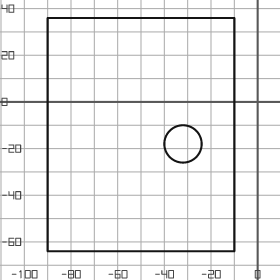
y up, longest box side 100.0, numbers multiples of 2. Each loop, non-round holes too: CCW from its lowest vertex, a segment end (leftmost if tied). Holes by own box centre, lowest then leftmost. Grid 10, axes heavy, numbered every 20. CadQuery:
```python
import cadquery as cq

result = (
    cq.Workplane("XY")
    .moveTo(-90.0, -64.0)
    .lineTo(-10.0, -64.0)
    .lineTo(-10.0, 36.0)
    .lineTo(-90.0, 36.0)
    .close()
    .moveTo(-32.0, -18.0)
    .circle(8.0)
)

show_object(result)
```